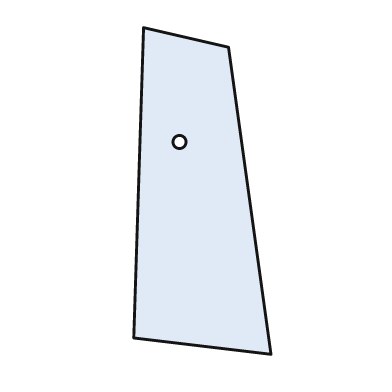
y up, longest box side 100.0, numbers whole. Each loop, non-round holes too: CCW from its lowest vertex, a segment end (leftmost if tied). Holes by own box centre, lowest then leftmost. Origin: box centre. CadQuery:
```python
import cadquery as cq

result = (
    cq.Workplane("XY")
    .moveTo(21.0, -50.0)
    .lineTo(8.0, 44.0)
    .lineTo(-18.0, 50.0)
    .lineTo(-21.0, -45.0)
    .close()
    .moveTo(-7.0, 15.0)
    .circle(2.0)
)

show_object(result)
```